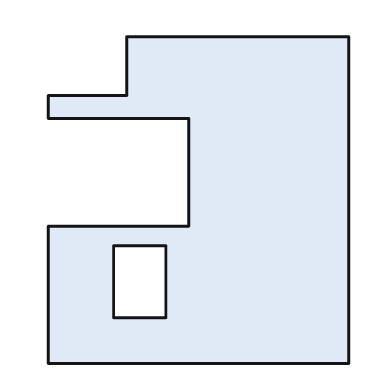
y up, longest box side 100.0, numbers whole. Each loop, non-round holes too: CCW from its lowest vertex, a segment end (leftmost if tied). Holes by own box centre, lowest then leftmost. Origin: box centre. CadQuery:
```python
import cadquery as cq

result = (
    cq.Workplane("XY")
    .moveTo(-46.0, -50.0)
    .lineTo(46.0, -50.0)
    .lineTo(46.0, 50.0)
    .lineTo(-22.0, 50.0)
    .lineTo(-22.0, 32.0)
    .lineTo(-46.0, 32.0)
    .lineTo(-46.0, 25.0)
    .lineTo(-3.0, 25.0)
    .lineTo(-3.0, -8.0)
    .lineTo(-46.0, -8.0)
    .close()
    .moveTo(-26.0, -36.0)
    .lineTo(-10.0, -36.0)
    .lineTo(-10.0, -14.0)
    .lineTo(-26.0, -14.0)
    .close()
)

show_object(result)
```